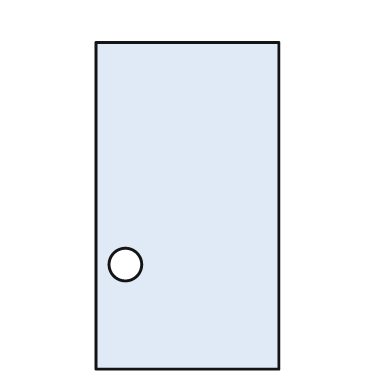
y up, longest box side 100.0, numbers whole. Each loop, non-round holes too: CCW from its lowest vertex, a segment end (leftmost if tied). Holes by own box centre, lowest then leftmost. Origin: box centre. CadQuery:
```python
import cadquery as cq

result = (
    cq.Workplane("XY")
    .moveTo(-28.0, -50.0)
    .lineTo(28.0, -50.0)
    .lineTo(28.0, 50.0)
    .lineTo(-28.0, 50.0)
    .close()
    .moveTo(-19.0, -18.0)
    .circle(5.0)
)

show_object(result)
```